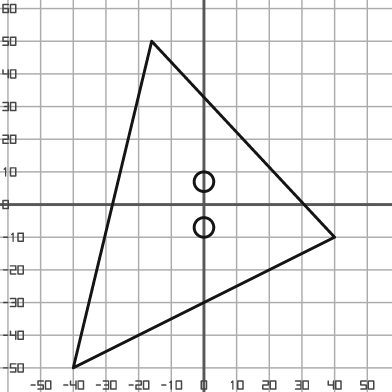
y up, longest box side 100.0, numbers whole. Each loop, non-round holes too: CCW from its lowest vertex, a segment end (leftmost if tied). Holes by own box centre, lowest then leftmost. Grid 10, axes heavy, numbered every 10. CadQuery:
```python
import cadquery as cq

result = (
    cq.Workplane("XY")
    .moveTo(-40.0, -50.0)
    .lineTo(40.0, -10.0)
    .lineTo(-16.0, 50.0)
    .close()
    .moveTo(0.0, -7.0)
    .circle(3.0)
    .moveTo(0.0, 7.0)
    .circle(3.0)
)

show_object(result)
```